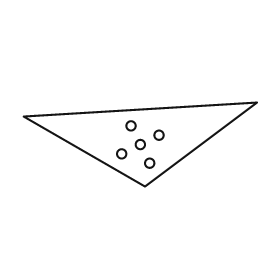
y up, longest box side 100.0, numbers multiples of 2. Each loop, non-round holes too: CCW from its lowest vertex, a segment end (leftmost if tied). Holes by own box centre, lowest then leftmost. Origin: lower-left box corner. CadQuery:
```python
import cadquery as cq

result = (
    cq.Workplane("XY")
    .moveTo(52.0, 0.0)
    .lineTo(100.0, 36.0)
    .lineTo(0.0, 30.0)
    .close()
    .moveTo(54.0, 10.0)
    .circle(2.0)
    .moveTo(42.0, 14.0)
    .circle(2.0)
    .moveTo(50.0, 18.0)
    .circle(2.0)
    .moveTo(58.0, 22.0)
    .circle(2.0)
    .moveTo(46.0, 26.0)
    .circle(2.0)
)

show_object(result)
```